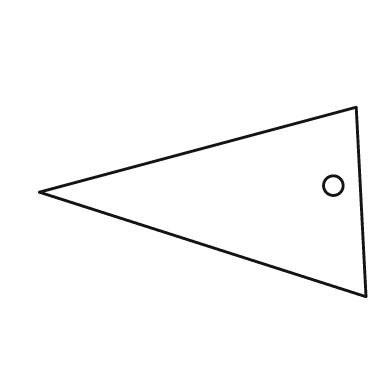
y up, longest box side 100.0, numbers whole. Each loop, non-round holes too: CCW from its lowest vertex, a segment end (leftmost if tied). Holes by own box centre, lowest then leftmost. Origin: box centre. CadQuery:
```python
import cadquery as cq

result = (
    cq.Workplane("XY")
    .moveTo(50.0, -29.0)
    .lineTo(47.0, 29.0)
    .lineTo(-50.0, 3.0)
    .close()
    .moveTo(40.0, 5.0)
    .circle(3.0)
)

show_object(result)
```